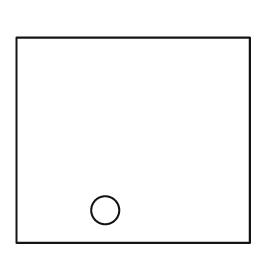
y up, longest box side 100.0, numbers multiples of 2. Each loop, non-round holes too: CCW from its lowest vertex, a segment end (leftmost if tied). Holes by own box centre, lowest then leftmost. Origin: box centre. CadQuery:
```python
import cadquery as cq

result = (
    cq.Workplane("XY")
    .moveTo(-50.0, -44.0)
    .lineTo(50.0, -44.0)
    .lineTo(50.0, 44.0)
    .lineTo(-50.0, 44.0)
    .close()
    .moveTo(-12.0, -30.0)
    .circle(6.0)
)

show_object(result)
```